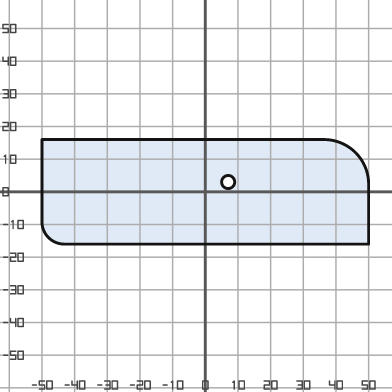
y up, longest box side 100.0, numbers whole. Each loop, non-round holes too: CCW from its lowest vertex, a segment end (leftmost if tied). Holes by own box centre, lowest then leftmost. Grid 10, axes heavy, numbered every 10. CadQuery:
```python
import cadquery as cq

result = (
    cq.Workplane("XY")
    .moveTo(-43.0, -16.0)
    .lineTo(50.0, -16.0)
    .lineTo(50.0, 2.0)
    .threePointArc((46.0, 12.0), (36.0, 16.0))
    .lineTo(-50.0, 16.0)
    .lineTo(-50.0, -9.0)
    .threePointArc((-48.0, -14.0), (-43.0, -16.0))
    .close()
    .moveTo(7.0, 3.0)
    .circle(2.0)
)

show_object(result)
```